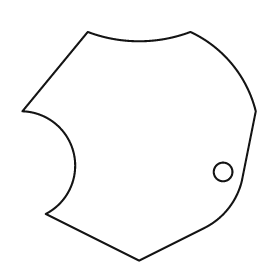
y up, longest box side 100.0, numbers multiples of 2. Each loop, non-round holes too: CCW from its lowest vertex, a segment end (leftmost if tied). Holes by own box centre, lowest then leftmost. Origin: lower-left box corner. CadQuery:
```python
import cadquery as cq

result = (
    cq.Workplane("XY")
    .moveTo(50.0, 0.0)
    .lineTo(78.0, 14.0)
    .threePointArc((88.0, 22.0), (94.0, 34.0))
    .lineTo(100.0, 64.0)
    .threePointArc((90.0, 84.0), (72.0, 98.0))
    .threePointArc((50.0, 94.0), (28.0, 98.0))
    .lineTo(0.0, 64.0)
    .threePointArc((22.0, 46.0), (10.0, 20.0))
    .close()
    .moveTo(86.0, 38.0)
    .circle(4.0)
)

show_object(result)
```